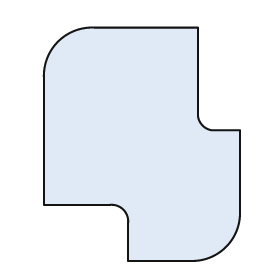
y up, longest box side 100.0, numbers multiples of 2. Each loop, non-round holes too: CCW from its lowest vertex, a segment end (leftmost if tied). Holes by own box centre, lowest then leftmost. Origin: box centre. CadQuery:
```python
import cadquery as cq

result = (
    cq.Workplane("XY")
    .moveTo(-6.0, -50.0)
    .lineTo(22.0, -50.0)
    .threePointArc((36.0, -44.0), (42.0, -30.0))
    .lineTo(42.0, 6.0)
    .lineTo(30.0, 6.0)
    .threePointArc((26.0, 8.0), (24.0, 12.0))
    .lineTo(24.0, 50.0)
    .lineTo(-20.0, 50.0)
    .threePointArc((-36.0, 44.0), (-42.0, 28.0))
    .lineTo(-42.0, -26.0)
    .lineTo(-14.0, -26.0)
    .threePointArc((-8.0, -28.0), (-6.0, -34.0))
    .close()
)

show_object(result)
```